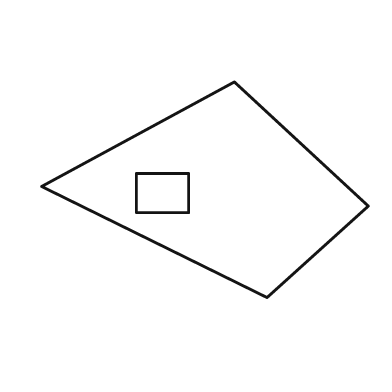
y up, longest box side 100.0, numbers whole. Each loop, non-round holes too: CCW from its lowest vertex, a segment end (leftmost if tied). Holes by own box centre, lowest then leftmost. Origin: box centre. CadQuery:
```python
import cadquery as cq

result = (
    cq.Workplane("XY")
    .moveTo(19.0, -33.0)
    .lineTo(50.0, -5.0)
    .lineTo(9.0, 33.0)
    .lineTo(-50.0, 1.0)
    .close()
    .moveTo(-21.0, -7.0)
    .lineTo(-5.0, -7.0)
    .lineTo(-5.0, 5.0)
    .lineTo(-21.0, 5.0)
    .close()
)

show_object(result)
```